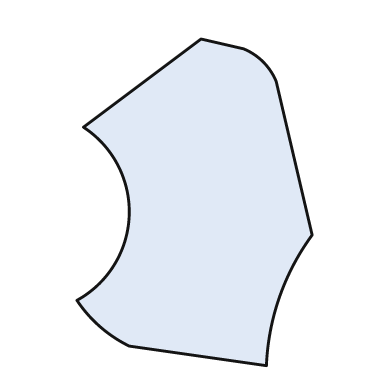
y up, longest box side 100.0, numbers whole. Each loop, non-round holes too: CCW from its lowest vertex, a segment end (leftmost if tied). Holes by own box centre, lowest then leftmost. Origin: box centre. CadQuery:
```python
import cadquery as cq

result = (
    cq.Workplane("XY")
    .moveTo(22.0, -50.0)
    .threePointArc((26.0, -29.0), (36.0, -10.0))
    .lineTo(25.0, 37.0)
    .threePointArc((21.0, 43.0), (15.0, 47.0))
    .lineTo(2.0, 50.0)
    .lineTo(-34.0, 23.0)
    .threePointArc((-20.0, -4.0), (-36.0, -30.0))
    .threePointArc((-29.0, -38.0), (-20.0, -44.0))
    .close()
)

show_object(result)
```